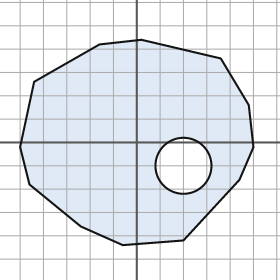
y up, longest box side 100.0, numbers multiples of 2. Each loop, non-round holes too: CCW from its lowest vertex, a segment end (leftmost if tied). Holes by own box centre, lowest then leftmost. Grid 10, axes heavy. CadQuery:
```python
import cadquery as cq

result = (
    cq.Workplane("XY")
    .moveTo(-6.0, -44.0)
    .lineTo(20.0, -42.0)
    .lineTo(44.0, -16.0)
    .lineTo(50.0, -2.0)
    .lineTo(48.0, 16.0)
    .lineTo(36.0, 36.0)
    .lineTo(2.0, 44.0)
    .lineTo(-16.0, 42.0)
    .lineTo(-44.0, 26.0)
    .lineTo(-50.0, -2.0)
    .lineTo(-46.0, -18.0)
    .lineTo(-24.0, -36.0)
    .close()
    .moveTo(20.0, -10.0)
    .circle(12.0)
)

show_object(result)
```